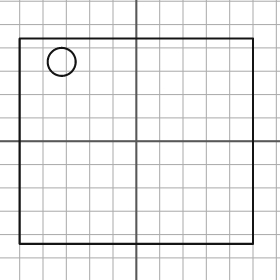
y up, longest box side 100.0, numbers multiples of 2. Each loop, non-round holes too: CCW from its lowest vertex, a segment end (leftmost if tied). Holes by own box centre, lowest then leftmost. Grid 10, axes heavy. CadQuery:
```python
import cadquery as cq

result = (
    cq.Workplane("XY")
    .moveTo(-50.0, -44.0)
    .lineTo(50.0, -44.0)
    .lineTo(50.0, 44.0)
    .lineTo(-50.0, 44.0)
    .close()
    .moveTo(-32.0, 34.0)
    .circle(6.0)
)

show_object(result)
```